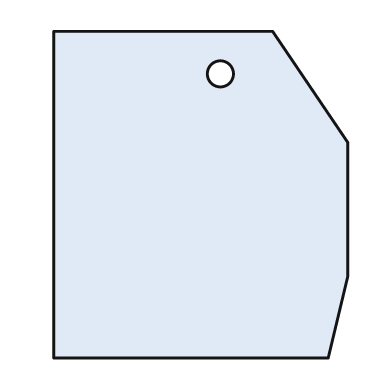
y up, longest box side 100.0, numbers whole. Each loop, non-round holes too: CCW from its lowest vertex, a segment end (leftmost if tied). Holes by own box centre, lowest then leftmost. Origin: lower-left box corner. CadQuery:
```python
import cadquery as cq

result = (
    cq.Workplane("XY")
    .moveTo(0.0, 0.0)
    .lineTo(84.0, 0.0)
    .lineTo(90.0, 25.0)
    .lineTo(90.0, 66.0)
    .lineTo(67.0, 100.0)
    .lineTo(0.0, 100.0)
    .close()
    .moveTo(51.0, 87.0)
    .circle(4.0)
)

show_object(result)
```